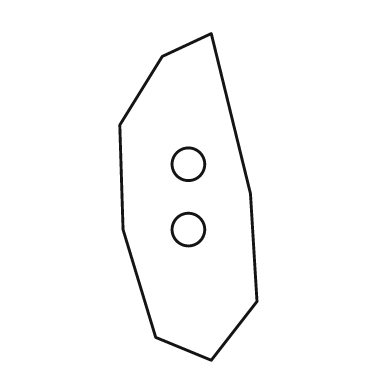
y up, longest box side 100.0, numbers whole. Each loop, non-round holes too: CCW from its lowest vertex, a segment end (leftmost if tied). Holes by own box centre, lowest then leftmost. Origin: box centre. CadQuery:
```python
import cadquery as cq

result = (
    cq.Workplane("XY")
    .moveTo(7.0, -50.0)
    .lineTo(21.0, -32.0)
    .lineTo(19.0, 1.0)
    .lineTo(7.0, 50.0)
    .lineTo(-8.0, 43.0)
    .lineTo(-21.0, 22.0)
    .lineTo(-20.0, -10.0)
    .lineTo(-10.0, -43.0)
    .close()
    .moveTo(0.0, -10.0)
    .circle(5.0)
    .moveTo(0.0, 10.0)
    .circle(5.0)
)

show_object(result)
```